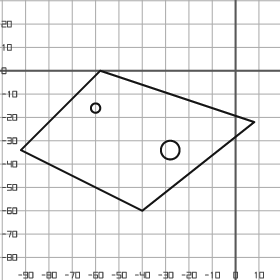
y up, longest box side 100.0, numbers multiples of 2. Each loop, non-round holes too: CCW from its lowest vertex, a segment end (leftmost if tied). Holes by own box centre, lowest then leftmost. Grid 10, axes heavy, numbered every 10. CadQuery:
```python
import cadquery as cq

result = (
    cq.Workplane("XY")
    .moveTo(-40.0, -60.0)
    .lineTo(8.0, -22.0)
    .lineTo(-58.0, 0.0)
    .lineTo(-92.0, -34.0)
    .close()
    .moveTo(-28.0, -34.0)
    .circle(4.0)
    .moveTo(-60.0, -16.0)
    .circle(2.0)
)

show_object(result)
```